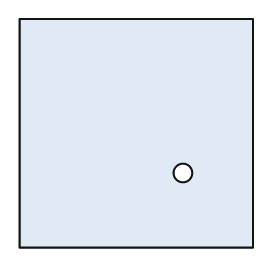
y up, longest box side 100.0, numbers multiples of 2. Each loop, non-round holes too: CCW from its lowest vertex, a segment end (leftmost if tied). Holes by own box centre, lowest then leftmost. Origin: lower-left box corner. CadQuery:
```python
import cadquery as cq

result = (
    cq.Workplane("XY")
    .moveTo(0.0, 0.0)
    .lineTo(100.0, 0.0)
    .lineTo(100.0, 98.0)
    .lineTo(0.0, 98.0)
    .close()
    .moveTo(70.0, 32.0)
    .circle(4.0)
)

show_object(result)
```